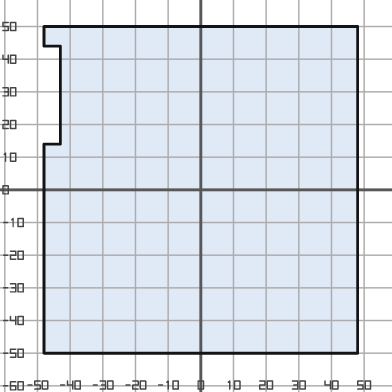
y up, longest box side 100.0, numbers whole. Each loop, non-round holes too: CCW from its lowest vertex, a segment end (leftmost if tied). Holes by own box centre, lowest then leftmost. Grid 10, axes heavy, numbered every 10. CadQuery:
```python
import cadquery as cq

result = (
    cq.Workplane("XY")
    .moveTo(-48.0, -50.0)
    .lineTo(48.0, -50.0)
    .lineTo(48.0, 50.0)
    .lineTo(-48.0, 50.0)
    .lineTo(-48.0, 44.0)
    .lineTo(-43.0, 44.0)
    .lineTo(-43.0, 14.0)
    .lineTo(-48.0, 14.0)
    .close()
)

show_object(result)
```